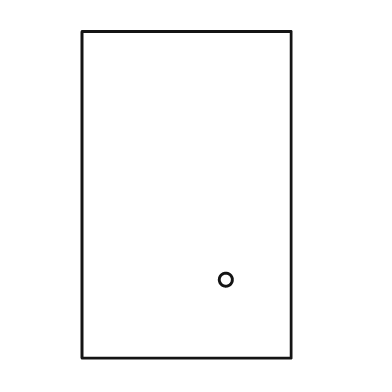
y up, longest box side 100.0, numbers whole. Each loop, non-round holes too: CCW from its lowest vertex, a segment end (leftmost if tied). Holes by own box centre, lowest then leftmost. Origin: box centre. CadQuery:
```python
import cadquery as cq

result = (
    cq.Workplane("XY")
    .moveTo(-32.0, -50.0)
    .lineTo(32.0, -50.0)
    .lineTo(32.0, 50.0)
    .lineTo(-32.0, 50.0)
    .close()
    .moveTo(12.0, -26.0)
    .circle(2.0)
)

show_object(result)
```